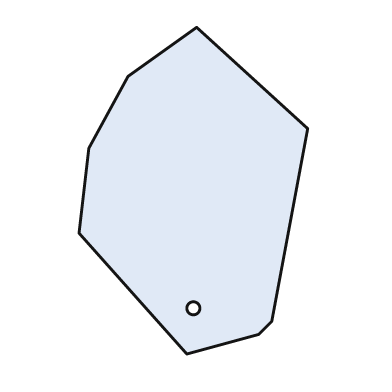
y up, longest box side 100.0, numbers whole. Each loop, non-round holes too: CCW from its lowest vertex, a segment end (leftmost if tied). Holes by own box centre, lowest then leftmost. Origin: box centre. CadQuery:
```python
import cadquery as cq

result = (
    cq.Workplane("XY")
    .moveTo(-2.0, -50.0)
    .lineTo(20.0, -44.0)
    .lineTo(24.0, -40.0)
    .lineTo(35.0, 19.0)
    .lineTo(1.0, 50.0)
    .lineTo(-20.0, 35.0)
    .lineTo(-32.0, 13.0)
    .lineTo(-35.0, -13.0)
    .close()
    .moveTo(0.0, -36.0)
    .circle(2.0)
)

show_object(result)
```